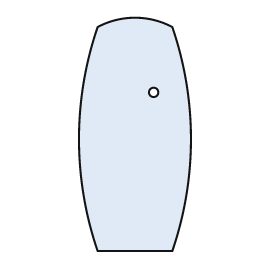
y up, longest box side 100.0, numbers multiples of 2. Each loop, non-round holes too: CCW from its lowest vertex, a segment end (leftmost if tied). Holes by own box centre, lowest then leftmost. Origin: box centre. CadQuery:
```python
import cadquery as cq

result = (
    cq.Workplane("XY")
    .moveTo(-16.0, -50.0)
    .lineTo(16.0, -50.0)
    .threePointArc((24.0, -2.0), (16.0, 46.0))
    .threePointArc((0.0, 50.0), (-16.0, 46.0))
    .threePointArc((-24.0, -2.0), (-16.0, -50.0))
    .close()
    .moveTo(8.0, 18.0)
    .circle(2.0)
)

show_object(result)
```